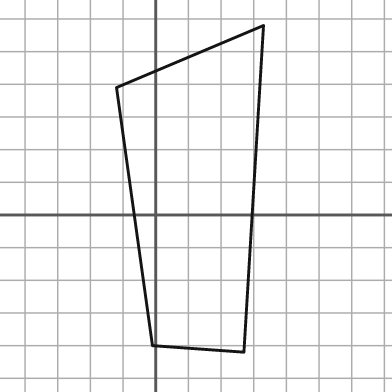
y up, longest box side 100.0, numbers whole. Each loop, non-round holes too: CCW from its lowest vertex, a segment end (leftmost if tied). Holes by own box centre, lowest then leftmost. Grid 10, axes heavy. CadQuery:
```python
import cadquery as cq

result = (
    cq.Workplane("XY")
    .moveTo(27.0, -42.0)
    .lineTo(33.0, 58.0)
    .lineTo(-12.0, 39.0)
    .lineTo(-1.0, -40.0)
    .close()
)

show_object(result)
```